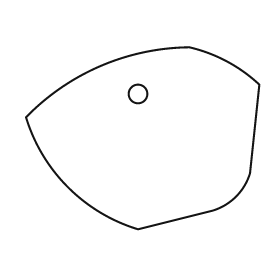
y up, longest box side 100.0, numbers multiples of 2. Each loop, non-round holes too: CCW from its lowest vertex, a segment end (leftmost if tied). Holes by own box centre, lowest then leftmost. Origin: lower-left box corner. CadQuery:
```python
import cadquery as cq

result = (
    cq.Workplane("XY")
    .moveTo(48.0, 0.0)
    .lineTo(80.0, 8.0)
    .threePointArc((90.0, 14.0), (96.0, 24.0))
    .lineTo(100.0, 62.0)
    .threePointArc((86.0, 72.0), (70.0, 78.0))
    .threePointArc((32.0, 70.0), (0.0, 48.0))
    .threePointArc((18.0, 18.0), (48.0, 0.0))
    .close()
    .moveTo(48.0, 58.0)
    .circle(4.0)
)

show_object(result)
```